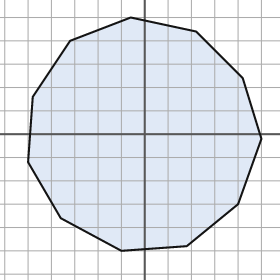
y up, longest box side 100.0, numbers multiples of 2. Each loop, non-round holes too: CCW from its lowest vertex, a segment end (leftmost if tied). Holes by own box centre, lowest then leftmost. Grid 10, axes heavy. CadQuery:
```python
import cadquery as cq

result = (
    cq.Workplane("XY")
    .moveTo(-10.0, -50.0)
    .lineTo(18.0, -48.0)
    .lineTo(40.0, -30.0)
    .lineTo(50.0, -2.0)
    .lineTo(42.0, 24.0)
    .lineTo(22.0, 44.0)
    .lineTo(-6.0, 50.0)
    .lineTo(-32.0, 40.0)
    .lineTo(-48.0, 16.0)
    .lineTo(-50.0, -12.0)
    .lineTo(-36.0, -36.0)
    .close()
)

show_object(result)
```